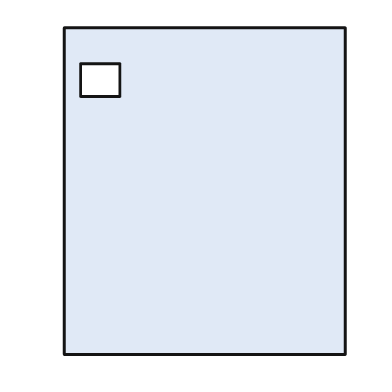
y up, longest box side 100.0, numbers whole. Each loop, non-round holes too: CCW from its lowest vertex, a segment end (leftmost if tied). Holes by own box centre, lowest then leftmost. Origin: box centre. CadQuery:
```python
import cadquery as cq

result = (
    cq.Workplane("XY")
    .moveTo(-43.0, -50.0)
    .lineTo(43.0, -50.0)
    .lineTo(43.0, 50.0)
    .lineTo(-43.0, 50.0)
    .close()
    .moveTo(-38.0, 29.0)
    .lineTo(-26.0, 29.0)
    .lineTo(-26.0, 39.0)
    .lineTo(-38.0, 39.0)
    .close()
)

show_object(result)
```